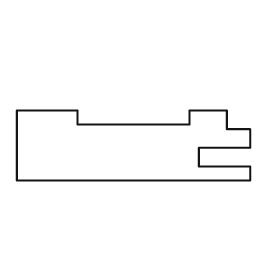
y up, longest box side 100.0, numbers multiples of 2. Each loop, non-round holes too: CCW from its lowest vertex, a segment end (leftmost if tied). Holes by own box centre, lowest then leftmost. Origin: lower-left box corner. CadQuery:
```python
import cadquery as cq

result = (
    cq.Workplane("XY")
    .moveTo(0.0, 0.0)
    .lineTo(100.0, 0.0)
    .lineTo(100.0, 6.0)
    .lineTo(78.0, 6.0)
    .lineTo(78.0, 14.0)
    .lineTo(100.0, 14.0)
    .lineTo(100.0, 22.0)
    .lineTo(90.0, 22.0)
    .lineTo(90.0, 30.0)
    .lineTo(74.0, 30.0)
    .lineTo(74.0, 24.0)
    .lineTo(26.0, 24.0)
    .lineTo(26.0, 30.0)
    .lineTo(0.0, 30.0)
    .close()
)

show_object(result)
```